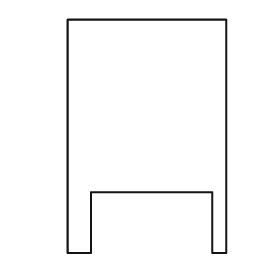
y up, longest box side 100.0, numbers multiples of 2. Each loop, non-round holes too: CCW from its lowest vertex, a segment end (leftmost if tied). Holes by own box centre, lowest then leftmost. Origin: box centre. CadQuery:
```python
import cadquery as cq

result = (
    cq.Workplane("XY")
    .moveTo(-34.0, -50.0)
    .lineTo(-24.0, -50.0)
    .lineTo(-24.0, -24.0)
    .lineTo(28.0, -24.0)
    .lineTo(28.0, -50.0)
    .lineTo(34.0, -50.0)
    .lineTo(34.0, 50.0)
    .lineTo(-34.0, 50.0)
    .close()
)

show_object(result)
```